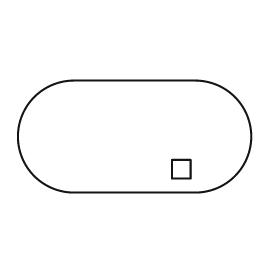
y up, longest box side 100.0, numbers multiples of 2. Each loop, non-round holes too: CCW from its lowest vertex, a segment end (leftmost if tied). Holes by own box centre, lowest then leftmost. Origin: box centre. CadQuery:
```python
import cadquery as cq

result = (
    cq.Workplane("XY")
    .moveTo(-26.0, -24.0)
    .lineTo(26.0, -24.0)
    .threePointArc((50.0, 0.0), (26.0, 24.0))
    .lineTo(-26.0, 24.0)
    .threePointArc((-50.0, 0.0), (-26.0, -24.0))
    .close()
    .moveTo(16.0, -18.0)
    .lineTo(24.0, -18.0)
    .lineTo(24.0, -10.0)
    .lineTo(16.0, -10.0)
    .close()
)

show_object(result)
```